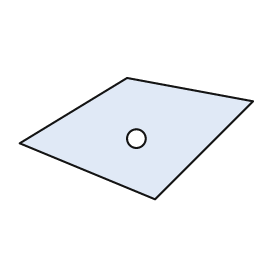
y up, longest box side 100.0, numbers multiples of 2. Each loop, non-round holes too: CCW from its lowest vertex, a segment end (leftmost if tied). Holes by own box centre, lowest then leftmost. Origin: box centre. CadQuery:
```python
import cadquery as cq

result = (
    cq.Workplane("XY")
    .moveTo(8.0, -26.0)
    .lineTo(50.0, 16.0)
    .lineTo(-4.0, 26.0)
    .lineTo(-50.0, -2.0)
    .close()
    .moveTo(0.0, 0.0)
    .circle(4.0)
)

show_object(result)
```